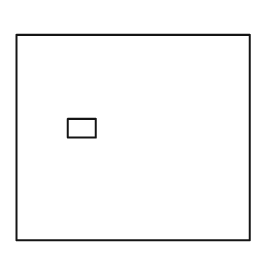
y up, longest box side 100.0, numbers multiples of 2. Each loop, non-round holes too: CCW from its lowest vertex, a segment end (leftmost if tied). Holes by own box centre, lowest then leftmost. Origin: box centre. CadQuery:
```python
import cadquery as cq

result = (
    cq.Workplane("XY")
    .moveTo(-50.0, -44.0)
    .lineTo(50.0, -44.0)
    .lineTo(50.0, 44.0)
    .lineTo(-50.0, 44.0)
    .close()
    .moveTo(-28.0, 0.0)
    .lineTo(-16.0, 0.0)
    .lineTo(-16.0, 8.0)
    .lineTo(-28.0, 8.0)
    .close()
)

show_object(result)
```